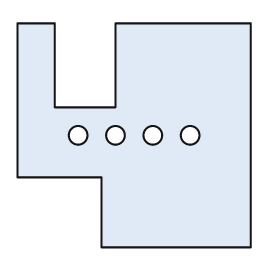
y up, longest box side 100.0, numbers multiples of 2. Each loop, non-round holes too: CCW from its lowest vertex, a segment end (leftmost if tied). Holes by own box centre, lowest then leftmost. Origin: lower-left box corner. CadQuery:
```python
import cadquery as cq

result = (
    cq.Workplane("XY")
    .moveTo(36.0, 0.0)
    .lineTo(100.0, 0.0)
    .lineTo(100.0, 96.0)
    .lineTo(42.0, 96.0)
    .lineTo(42.0, 60.0)
    .lineTo(16.0, 60.0)
    .lineTo(16.0, 96.0)
    .lineTo(0.0, 96.0)
    .lineTo(0.0, 30.0)
    .lineTo(36.0, 30.0)
    .close()
    .moveTo(26.0, 48.0)
    .circle(4.0)
    .moveTo(42.0, 48.0)
    .circle(4.0)
    .moveTo(58.0, 48.0)
    .circle(4.0)
    .moveTo(74.0, 48.0)
    .circle(4.0)
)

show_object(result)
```